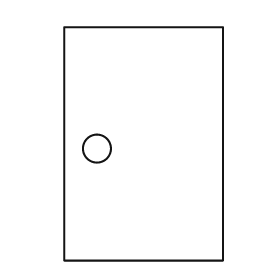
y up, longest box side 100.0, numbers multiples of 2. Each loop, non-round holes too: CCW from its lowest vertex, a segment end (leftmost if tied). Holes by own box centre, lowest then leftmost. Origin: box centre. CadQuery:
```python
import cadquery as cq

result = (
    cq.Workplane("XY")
    .moveTo(-34.0, -50.0)
    .lineTo(34.0, -50.0)
    .lineTo(34.0, 50.0)
    .lineTo(-34.0, 50.0)
    .close()
    .moveTo(-20.0, -2.0)
    .circle(6.0)
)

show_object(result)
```